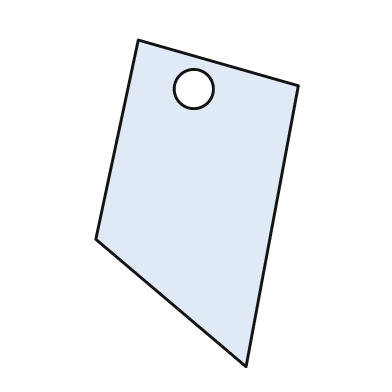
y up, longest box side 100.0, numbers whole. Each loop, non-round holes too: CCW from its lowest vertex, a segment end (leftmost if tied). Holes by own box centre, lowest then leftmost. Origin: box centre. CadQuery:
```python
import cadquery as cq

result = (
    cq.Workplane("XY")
    .moveTo(15.0, -50.0)
    .lineTo(31.0, 36.0)
    .lineTo(-18.0, 50.0)
    .lineTo(-31.0, -11.0)
    .close()
    .moveTo(-1.0, 35.0)
    .circle(6.0)
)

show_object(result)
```